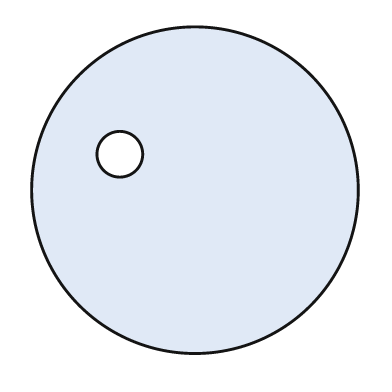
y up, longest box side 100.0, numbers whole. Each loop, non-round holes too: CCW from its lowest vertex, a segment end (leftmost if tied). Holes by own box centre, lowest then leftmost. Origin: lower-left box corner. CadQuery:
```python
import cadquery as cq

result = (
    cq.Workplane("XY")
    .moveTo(50.0, 50.0)
    .circle(50.0)
    .moveTo(27.0, 61.0)
    .circle(7.0)
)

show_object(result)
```